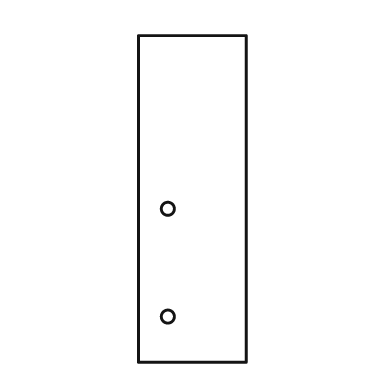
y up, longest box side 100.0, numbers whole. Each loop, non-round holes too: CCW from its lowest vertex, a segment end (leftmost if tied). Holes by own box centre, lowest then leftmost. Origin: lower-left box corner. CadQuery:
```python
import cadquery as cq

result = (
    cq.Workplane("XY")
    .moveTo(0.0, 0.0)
    .lineTo(33.0, 0.0)
    .lineTo(33.0, 100.0)
    .lineTo(0.0, 100.0)
    .close()
    .moveTo(9.0, 14.0)
    .circle(2.0)
    .moveTo(9.0, 47.0)
    .circle(2.0)
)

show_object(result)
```